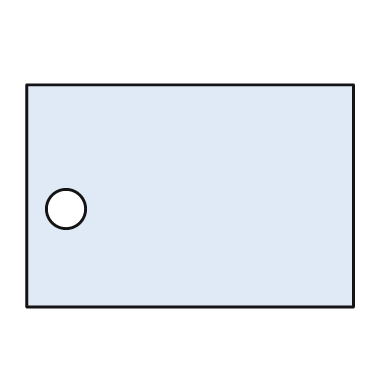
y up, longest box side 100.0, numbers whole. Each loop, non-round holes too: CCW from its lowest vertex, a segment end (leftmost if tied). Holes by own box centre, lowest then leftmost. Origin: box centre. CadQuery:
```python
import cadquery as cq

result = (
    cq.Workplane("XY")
    .moveTo(-50.0, -34.0)
    .lineTo(50.0, -34.0)
    .lineTo(50.0, 34.0)
    .lineTo(-50.0, 34.0)
    .close()
    .moveTo(-38.0, -4.0)
    .circle(6.0)
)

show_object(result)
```